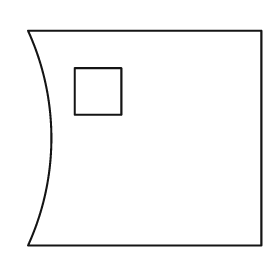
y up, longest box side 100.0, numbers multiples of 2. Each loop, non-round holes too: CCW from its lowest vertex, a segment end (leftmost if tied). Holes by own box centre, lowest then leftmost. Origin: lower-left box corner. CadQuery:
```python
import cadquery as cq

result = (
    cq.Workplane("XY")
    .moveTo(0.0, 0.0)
    .lineTo(100.0, 0.0)
    .lineTo(100.0, 92.0)
    .lineTo(0.0, 92.0)
    .threePointArc((10.0, 46.0), (0.0, 0.0))
    .close()
    .moveTo(20.0, 56.0)
    .lineTo(40.0, 56.0)
    .lineTo(40.0, 76.0)
    .lineTo(20.0, 76.0)
    .close()
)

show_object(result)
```